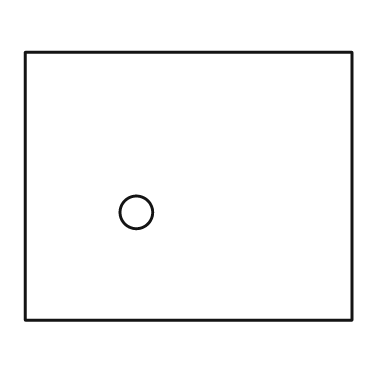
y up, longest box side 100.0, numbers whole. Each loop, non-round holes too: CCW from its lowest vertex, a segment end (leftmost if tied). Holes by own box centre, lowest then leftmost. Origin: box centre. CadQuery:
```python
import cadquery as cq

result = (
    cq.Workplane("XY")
    .moveTo(-50.0, -41.0)
    .lineTo(50.0, -41.0)
    .lineTo(50.0, 41.0)
    .lineTo(-50.0, 41.0)
    .close()
    .moveTo(-16.0, -8.0)
    .circle(5.0)
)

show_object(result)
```